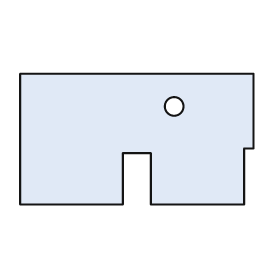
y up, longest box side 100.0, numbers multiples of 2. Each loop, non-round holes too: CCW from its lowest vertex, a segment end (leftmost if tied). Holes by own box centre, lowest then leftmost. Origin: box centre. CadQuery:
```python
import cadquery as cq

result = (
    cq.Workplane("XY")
    .moveTo(-50.0, -28.0)
    .lineTo(-6.0, -28.0)
    .lineTo(-6.0, -6.0)
    .lineTo(6.0, -6.0)
    .lineTo(6.0, -28.0)
    .lineTo(46.0, -28.0)
    .lineTo(46.0, -4.0)
    .lineTo(50.0, -4.0)
    .lineTo(50.0, 28.0)
    .lineTo(-50.0, 28.0)
    .close()
    .moveTo(16.0, 14.0)
    .circle(4.0)
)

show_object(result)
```